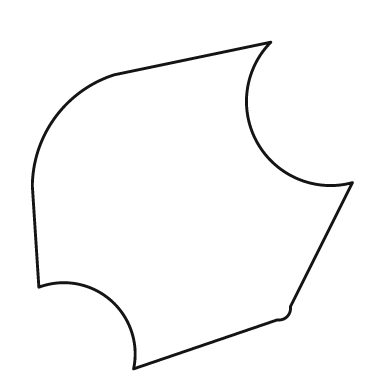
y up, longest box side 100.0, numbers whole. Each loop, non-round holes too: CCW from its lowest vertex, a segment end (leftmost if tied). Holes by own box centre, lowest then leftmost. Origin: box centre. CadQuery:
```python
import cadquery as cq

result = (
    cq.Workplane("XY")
    .moveTo(-18.0, -50.0)
    .lineTo(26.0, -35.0)
    .threePointArc((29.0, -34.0), (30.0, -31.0))
    .lineTo(49.0, 7.0)
    .threePointArc((20.0, 19.0), (24.0, 50.0))
    .lineTo(-24.0, 40.0)
    .threePointArc((-42.0, 27.0), (-49.0, 6.0))
    .lineTo(-47.0, -25.0)
    .threePointArc((-25.0, -29.0), (-18.0, -50.0))
    .close()
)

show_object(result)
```